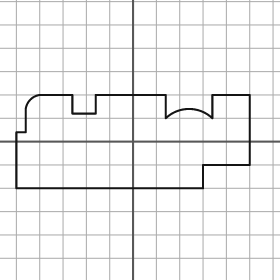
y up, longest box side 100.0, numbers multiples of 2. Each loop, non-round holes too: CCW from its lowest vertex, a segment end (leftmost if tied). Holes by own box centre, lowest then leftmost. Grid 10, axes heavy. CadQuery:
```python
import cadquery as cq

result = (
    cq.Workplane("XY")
    .moveTo(-50.0, -20.0)
    .lineTo(30.0, -20.0)
    .lineTo(30.0, -10.0)
    .lineTo(50.0, -10.0)
    .lineTo(50.0, 20.0)
    .lineTo(34.0, 20.0)
    .lineTo(34.0, 10.0)
    .threePointArc((24.0, 14.0), (14.0, 10.0))
    .lineTo(14.0, 20.0)
    .lineTo(-16.0, 20.0)
    .lineTo(-16.0, 12.0)
    .lineTo(-26.0, 12.0)
    .lineTo(-26.0, 20.0)
    .lineTo(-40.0, 20.0)
    .threePointArc((-44.0, 18.0), (-46.0, 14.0))
    .lineTo(-46.0, 4.0)
    .lineTo(-50.0, 4.0)
    .close()
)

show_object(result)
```